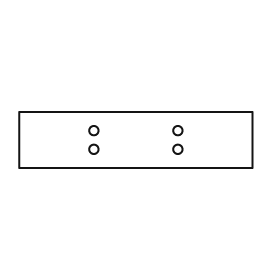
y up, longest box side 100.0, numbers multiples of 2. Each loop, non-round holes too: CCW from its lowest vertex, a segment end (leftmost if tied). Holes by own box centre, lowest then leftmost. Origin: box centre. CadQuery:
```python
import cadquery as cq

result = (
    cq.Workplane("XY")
    .moveTo(-50.0, -12.0)
    .lineTo(50.0, -12.0)
    .lineTo(50.0, 12.0)
    .lineTo(-50.0, 12.0)
    .close()
    .moveTo(-18.0, -4.0)
    .circle(2.0)
    .moveTo(18.0, -4.0)
    .circle(2.0)
    .moveTo(-18.0, 4.0)
    .circle(2.0)
    .moveTo(18.0, 4.0)
    .circle(2.0)
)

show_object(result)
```